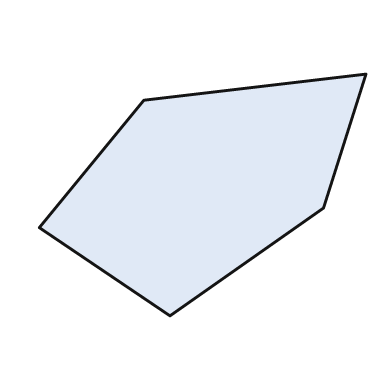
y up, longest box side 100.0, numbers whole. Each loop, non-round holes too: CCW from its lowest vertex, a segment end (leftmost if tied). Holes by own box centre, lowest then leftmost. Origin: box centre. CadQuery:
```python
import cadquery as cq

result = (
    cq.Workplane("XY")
    .moveTo(-10.0, -37.0)
    .lineTo(37.0, -4.0)
    .lineTo(50.0, 37.0)
    .lineTo(-18.0, 29.0)
    .lineTo(-50.0, -10.0)
    .close()
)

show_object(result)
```